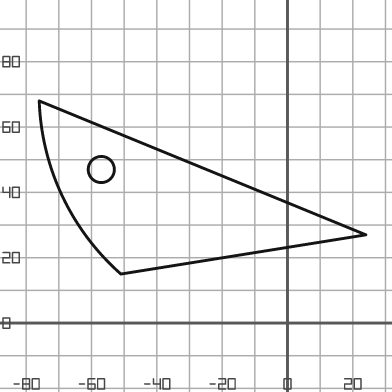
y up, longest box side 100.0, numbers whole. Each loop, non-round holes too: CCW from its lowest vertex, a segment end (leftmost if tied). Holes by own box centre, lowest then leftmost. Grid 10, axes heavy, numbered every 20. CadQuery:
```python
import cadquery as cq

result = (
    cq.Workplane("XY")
    .moveTo(-51.0, 15.0)
    .lineTo(24.0, 27.0)
    .lineTo(-76.0, 68.0)
    .threePointArc((-69.0, 39.0), (-51.0, 15.0))
    .close()
    .moveTo(-57.0, 47.0)
    .circle(4.0)
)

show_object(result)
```